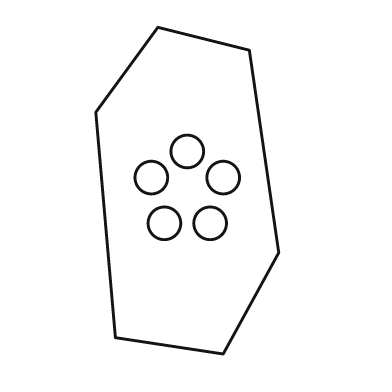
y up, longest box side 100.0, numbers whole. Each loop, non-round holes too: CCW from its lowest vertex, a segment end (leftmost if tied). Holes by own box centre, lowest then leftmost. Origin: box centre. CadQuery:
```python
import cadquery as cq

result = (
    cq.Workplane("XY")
    .moveTo(11.0, -50.0)
    .lineTo(28.0, -19.0)
    .lineTo(19.0, 43.0)
    .lineTo(-9.0, 50.0)
    .lineTo(-28.0, 24.0)
    .lineTo(-22.0, -45.0)
    .close()
    .moveTo(-7.0, -10.0)
    .circle(5.0)
    .moveTo(7.0, -10.0)
    .circle(5.0)
    .moveTo(-11.0, 4.0)
    .circle(5.0)
    .moveTo(11.0, 4.0)
    .circle(5.0)
    .moveTo(0.0, 12.0)
    .circle(5.0)
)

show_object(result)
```